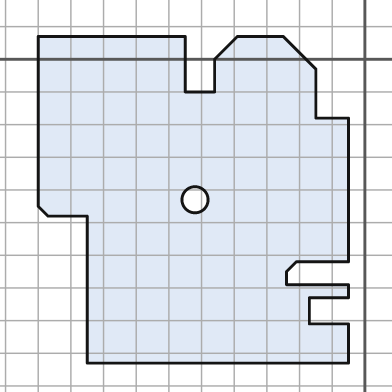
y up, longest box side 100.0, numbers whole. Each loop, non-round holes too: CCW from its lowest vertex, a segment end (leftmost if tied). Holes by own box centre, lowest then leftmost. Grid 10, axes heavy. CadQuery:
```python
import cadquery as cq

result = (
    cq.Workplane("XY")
    .moveTo(-85.0, -93.0)
    .lineTo(-5.0, -93.0)
    .lineTo(-5.0, -81.0)
    .lineTo(-17.0, -81.0)
    .lineTo(-17.0, -73.0)
    .lineTo(-5.0, -73.0)
    .lineTo(-5.0, -69.0)
    .lineTo(-24.0, -69.0)
    .lineTo(-24.0, -65.0)
    .lineTo(-21.0, -62.0)
    .lineTo(-5.0, -62.0)
    .lineTo(-5.0, -18.0)
    .lineTo(-15.0, -18.0)
    .lineTo(-15.0, -3.0)
    .lineTo(-25.0, 7.0)
    .lineTo(-39.0, 7.0)
    .lineTo(-46.0, 0.0)
    .lineTo(-46.0, -10.0)
    .lineTo(-55.0, -10.0)
    .lineTo(-55.0, 7.0)
    .lineTo(-100.0, 7.0)
    .lineTo(-100.0, -45.0)
    .lineTo(-97.0, -48.0)
    .lineTo(-85.0, -48.0)
    .close()
    .moveTo(-52.0, -43.0)
    .circle(4.0)
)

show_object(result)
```